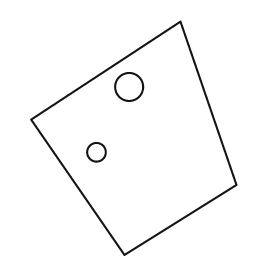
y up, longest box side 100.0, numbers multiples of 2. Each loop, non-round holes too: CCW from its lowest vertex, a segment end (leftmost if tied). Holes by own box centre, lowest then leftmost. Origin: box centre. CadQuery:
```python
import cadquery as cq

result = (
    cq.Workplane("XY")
    .moveTo(-4.0, -50.0)
    .lineTo(44.0, -20.0)
    .lineTo(20.0, 50.0)
    .lineTo(-44.0, 8.0)
    .close()
    .moveTo(-16.0, -6.0)
    .circle(4.0)
    .moveTo(-2.0, 22.0)
    .circle(6.0)
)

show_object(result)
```